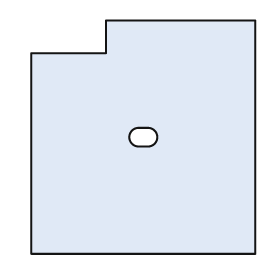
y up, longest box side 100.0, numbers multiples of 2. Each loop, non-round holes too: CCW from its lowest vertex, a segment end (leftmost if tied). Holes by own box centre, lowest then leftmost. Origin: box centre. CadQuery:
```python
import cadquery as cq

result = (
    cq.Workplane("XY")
    .moveTo(-48.0, -50.0)
    .lineTo(48.0, -50.0)
    .lineTo(48.0, 50.0)
    .lineTo(-16.0, 50.0)
    .lineTo(-16.0, 36.0)
    .lineTo(-48.0, 36.0)
    .close()
    .moveTo(-2.0, -4.0)
    .lineTo(2.0, -4.0)
    .threePointArc((6.0, 0.0), (2.0, 4.0))
    .lineTo(-2.0, 4.0)
    .threePointArc((-6.0, 0.0), (-2.0, -4.0))
    .close()
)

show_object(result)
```